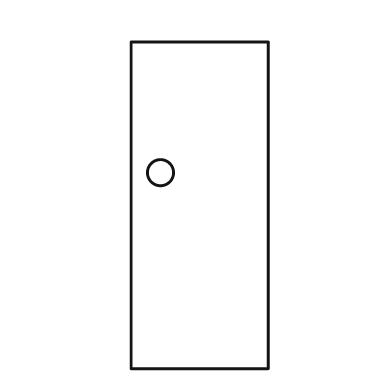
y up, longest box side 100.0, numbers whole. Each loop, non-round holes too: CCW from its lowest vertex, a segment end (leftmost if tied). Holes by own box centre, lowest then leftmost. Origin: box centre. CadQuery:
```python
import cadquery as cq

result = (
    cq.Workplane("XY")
    .moveTo(-21.0, -50.0)
    .lineTo(21.0, -50.0)
    .lineTo(21.0, 50.0)
    .lineTo(-21.0, 50.0)
    .close()
    .moveTo(-12.0, 10.0)
    .circle(4.0)
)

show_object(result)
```